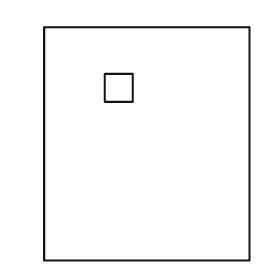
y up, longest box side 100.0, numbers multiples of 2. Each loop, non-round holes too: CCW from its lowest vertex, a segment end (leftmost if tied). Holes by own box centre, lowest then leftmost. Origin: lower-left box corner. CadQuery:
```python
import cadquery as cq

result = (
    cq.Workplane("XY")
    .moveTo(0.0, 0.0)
    .lineTo(88.0, 0.0)
    .lineTo(88.0, 100.0)
    .lineTo(0.0, 100.0)
    .close()
    .moveTo(26.0, 68.0)
    .lineTo(38.0, 68.0)
    .lineTo(38.0, 80.0)
    .lineTo(26.0, 80.0)
    .close()
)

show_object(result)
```